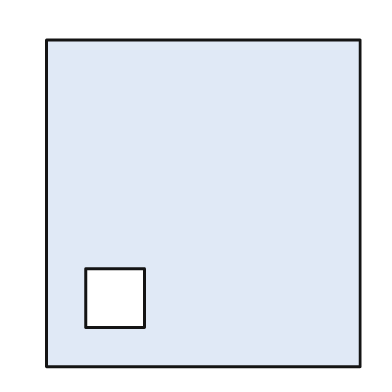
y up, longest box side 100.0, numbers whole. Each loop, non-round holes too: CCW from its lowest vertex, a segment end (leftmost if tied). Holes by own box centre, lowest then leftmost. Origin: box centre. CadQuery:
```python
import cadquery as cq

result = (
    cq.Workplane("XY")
    .moveTo(-48.0, -50.0)
    .lineTo(48.0, -50.0)
    .lineTo(48.0, 50.0)
    .lineTo(-48.0, 50.0)
    .close()
    .moveTo(-36.0, -38.0)
    .lineTo(-18.0, -38.0)
    .lineTo(-18.0, -20.0)
    .lineTo(-36.0, -20.0)
    .close()
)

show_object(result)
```